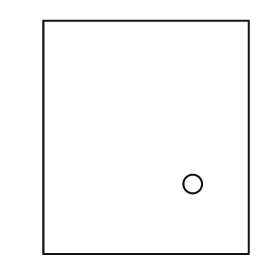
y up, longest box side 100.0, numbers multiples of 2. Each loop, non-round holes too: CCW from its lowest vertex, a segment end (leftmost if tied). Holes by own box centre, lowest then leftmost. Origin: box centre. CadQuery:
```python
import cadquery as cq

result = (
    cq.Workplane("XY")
    .moveTo(-44.0, -50.0)
    .lineTo(44.0, -50.0)
    .lineTo(44.0, 50.0)
    .lineTo(-44.0, 50.0)
    .close()
    .moveTo(20.0, -20.0)
    .circle(4.0)
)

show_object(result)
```